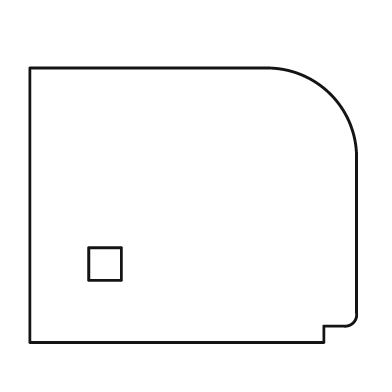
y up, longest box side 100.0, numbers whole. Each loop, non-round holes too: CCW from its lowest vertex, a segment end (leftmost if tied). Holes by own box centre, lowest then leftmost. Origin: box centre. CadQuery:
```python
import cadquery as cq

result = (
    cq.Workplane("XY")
    .moveTo(-50.0, -42.0)
    .lineTo(40.0, -42.0)
    .lineTo(40.0, -37.0)
    .lineTo(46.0, -37.0)
    .threePointArc((49.0, -36.0), (50.0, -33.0))
    .lineTo(50.0, 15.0)
    .threePointArc((42.0, 34.0), (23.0, 42.0))
    .lineTo(-50.0, 42.0)
    .close()
    .moveTo(-32.0, -23.0)
    .lineTo(-22.0, -23.0)
    .lineTo(-22.0, -13.0)
    .lineTo(-32.0, -13.0)
    .close()
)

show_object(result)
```